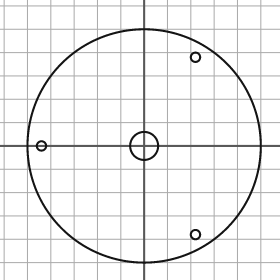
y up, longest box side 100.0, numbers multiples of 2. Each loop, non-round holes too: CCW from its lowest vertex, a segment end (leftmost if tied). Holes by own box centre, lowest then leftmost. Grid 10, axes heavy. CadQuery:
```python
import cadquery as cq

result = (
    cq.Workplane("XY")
    .moveTo(0.0, 0.0)
    .circle(50.0)
    .moveTo(22.0, -38.0)
    .circle(2.0)
    .moveTo(-44.0, 0.0)
    .circle(2.0)
    .moveTo(0.0, 0.0)
    .circle(6.0)
    .moveTo(22.0, 38.0)
    .circle(2.0)
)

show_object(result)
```